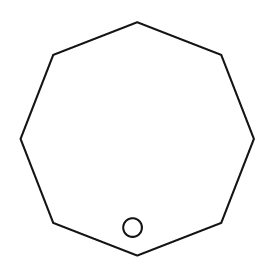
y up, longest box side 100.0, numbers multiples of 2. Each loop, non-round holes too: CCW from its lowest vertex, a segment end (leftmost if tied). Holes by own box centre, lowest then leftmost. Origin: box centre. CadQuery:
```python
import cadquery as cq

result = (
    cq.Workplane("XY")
    .moveTo(0.0, -50.0)
    .lineTo(36.0, -36.0)
    .lineTo(50.0, 0.0)
    .lineTo(36.0, 36.0)
    .lineTo(0.0, 50.0)
    .lineTo(-36.0, 36.0)
    .lineTo(-50.0, 0.0)
    .lineTo(-36.0, -36.0)
    .close()
    .moveTo(-2.0, -38.0)
    .circle(4.0)
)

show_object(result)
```